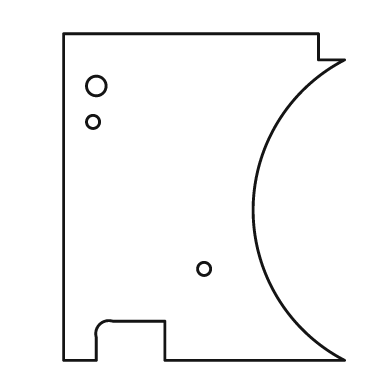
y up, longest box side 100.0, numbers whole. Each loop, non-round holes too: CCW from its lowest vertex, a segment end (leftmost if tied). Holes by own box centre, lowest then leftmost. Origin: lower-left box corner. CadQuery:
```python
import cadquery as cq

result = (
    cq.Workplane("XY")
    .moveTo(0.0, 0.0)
    .lineTo(10.0, 0.0)
    .lineTo(10.0, 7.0)
    .threePointArc((11.0, 11.0), (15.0, 12.0))
    .lineTo(31.0, 12.0)
    .lineTo(31.0, 0.0)
    .lineTo(86.0, 0.0)
    .threePointArc((58.0, 46.0), (86.0, 92.0))
    .lineTo(78.0, 92.0)
    .lineTo(78.0, 100.0)
    .lineTo(0.0, 100.0)
    .close()
    .moveTo(43.0, 28.0)
    .circle(2.0)
    .moveTo(9.0, 73.0)
    .circle(2.0)
    .moveTo(10.0, 84.0)
    .circle(3.0)
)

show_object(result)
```